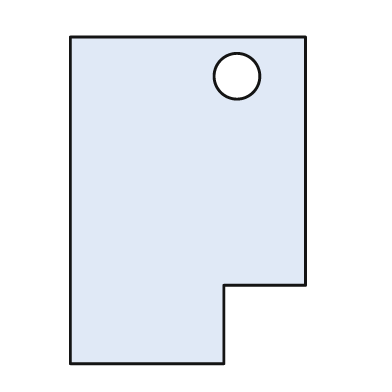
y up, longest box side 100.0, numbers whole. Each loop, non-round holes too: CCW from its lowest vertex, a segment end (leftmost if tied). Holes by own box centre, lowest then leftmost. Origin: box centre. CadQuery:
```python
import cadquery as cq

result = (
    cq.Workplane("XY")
    .moveTo(-36.0, -50.0)
    .lineTo(11.0, -50.0)
    .lineTo(11.0, -26.0)
    .lineTo(36.0, -26.0)
    .lineTo(36.0, 50.0)
    .lineTo(-36.0, 50.0)
    .close()
    .moveTo(15.0, 38.0)
    .circle(7.0)
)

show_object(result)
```